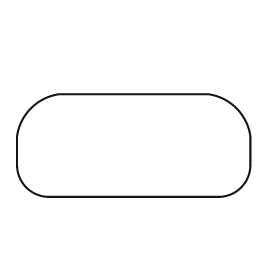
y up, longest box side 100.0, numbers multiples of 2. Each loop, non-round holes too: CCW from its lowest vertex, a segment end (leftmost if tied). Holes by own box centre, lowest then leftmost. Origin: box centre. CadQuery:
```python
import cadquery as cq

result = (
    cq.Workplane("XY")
    .moveTo(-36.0, -22.0)
    .lineTo(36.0, -22.0)
    .threePointArc((46.0, -18.0), (50.0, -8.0))
    .lineTo(50.0, 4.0)
    .threePointArc((44.0, 16.0), (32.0, 22.0))
    .lineTo(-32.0, 22.0)
    .threePointArc((-44.0, 16.0), (-50.0, 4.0))
    .lineTo(-50.0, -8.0)
    .threePointArc((-46.0, -18.0), (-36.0, -22.0))
    .close()
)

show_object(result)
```